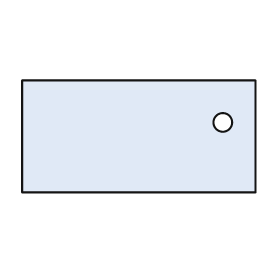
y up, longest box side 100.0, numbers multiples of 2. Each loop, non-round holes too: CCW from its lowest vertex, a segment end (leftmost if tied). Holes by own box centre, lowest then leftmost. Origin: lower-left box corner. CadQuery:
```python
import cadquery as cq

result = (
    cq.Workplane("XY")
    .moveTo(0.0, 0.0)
    .lineTo(100.0, 0.0)
    .lineTo(100.0, 48.0)
    .lineTo(0.0, 48.0)
    .close()
    .moveTo(86.0, 30.0)
    .circle(4.0)
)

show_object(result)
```